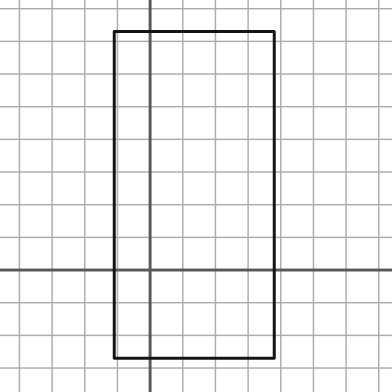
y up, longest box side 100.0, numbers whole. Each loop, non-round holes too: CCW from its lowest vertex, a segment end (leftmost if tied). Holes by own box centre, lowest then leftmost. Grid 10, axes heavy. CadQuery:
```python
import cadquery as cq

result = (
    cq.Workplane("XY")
    .moveTo(-11.0, -27.0)
    .lineTo(38.0, -27.0)
    .lineTo(38.0, 73.0)
    .lineTo(-11.0, 73.0)
    .close()
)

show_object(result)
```